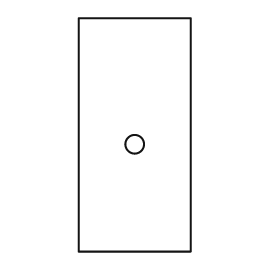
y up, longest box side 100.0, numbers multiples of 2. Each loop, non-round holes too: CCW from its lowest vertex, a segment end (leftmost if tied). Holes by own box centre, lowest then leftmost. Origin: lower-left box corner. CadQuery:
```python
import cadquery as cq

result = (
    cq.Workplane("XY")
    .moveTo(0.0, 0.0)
    .lineTo(48.0, 0.0)
    .lineTo(48.0, 100.0)
    .lineTo(0.0, 100.0)
    .close()
    .moveTo(24.0, 46.0)
    .circle(4.0)
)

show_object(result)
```